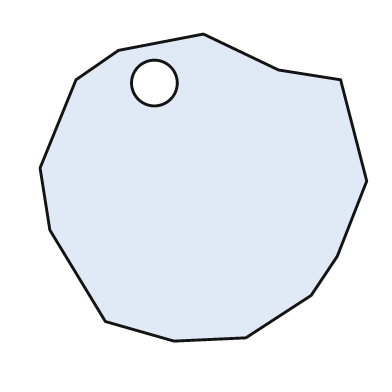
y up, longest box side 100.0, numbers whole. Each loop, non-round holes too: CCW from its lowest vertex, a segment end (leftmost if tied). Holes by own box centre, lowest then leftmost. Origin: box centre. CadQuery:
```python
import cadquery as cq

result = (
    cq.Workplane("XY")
    .moveTo(-9.0, -47.0)
    .lineTo(13.0, -46.0)
    .lineTo(33.0, -33.0)
    .lineTo(41.0, -21.0)
    .lineTo(50.0, 2.0)
    .lineTo(42.0, 33.0)
    .lineTo(23.0, 36.0)
    .lineTo(0.0, 47.0)
    .lineTo(-26.0, 42.0)
    .lineTo(-39.0, 33.0)
    .lineTo(-50.0, 6.0)
    .lineTo(-47.0, -13.0)
    .lineTo(-30.0, -41.0)
    .close()
    .moveTo(-15.0, 32.0)
    .circle(7.0)
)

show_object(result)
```